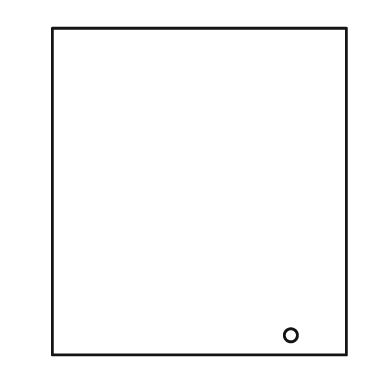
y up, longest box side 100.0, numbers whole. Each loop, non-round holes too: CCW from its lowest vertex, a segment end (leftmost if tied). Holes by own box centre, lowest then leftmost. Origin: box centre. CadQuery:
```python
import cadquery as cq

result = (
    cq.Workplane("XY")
    .moveTo(-45.0, -50.0)
    .lineTo(45.0, -50.0)
    .lineTo(45.0, 50.0)
    .lineTo(-45.0, 50.0)
    .close()
    .moveTo(28.0, -44.0)
    .circle(2.0)
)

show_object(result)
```